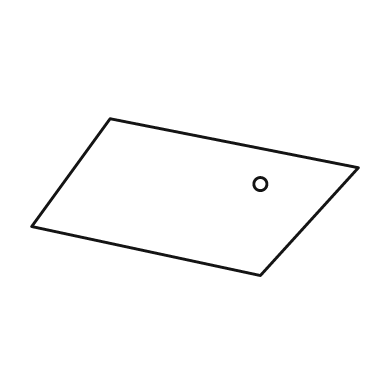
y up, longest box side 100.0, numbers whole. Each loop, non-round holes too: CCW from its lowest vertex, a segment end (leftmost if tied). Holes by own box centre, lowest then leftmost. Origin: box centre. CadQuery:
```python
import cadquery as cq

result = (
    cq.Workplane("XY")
    .moveTo(20.0, -24.0)
    .lineTo(50.0, 9.0)
    .lineTo(-26.0, 24.0)
    .lineTo(-50.0, -9.0)
    .close()
    .moveTo(20.0, 4.0)
    .circle(2.0)
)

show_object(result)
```